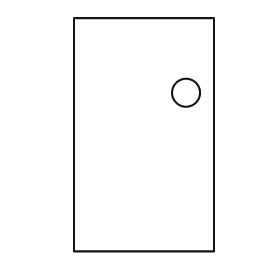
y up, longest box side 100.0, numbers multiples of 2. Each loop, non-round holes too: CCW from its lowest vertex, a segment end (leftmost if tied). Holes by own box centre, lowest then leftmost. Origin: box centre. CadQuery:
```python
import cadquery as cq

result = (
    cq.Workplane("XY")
    .moveTo(-30.0, -50.0)
    .lineTo(30.0, -50.0)
    .lineTo(30.0, 50.0)
    .lineTo(-30.0, 50.0)
    .close()
    .moveTo(18.0, 18.0)
    .circle(6.0)
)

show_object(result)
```